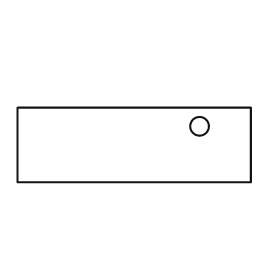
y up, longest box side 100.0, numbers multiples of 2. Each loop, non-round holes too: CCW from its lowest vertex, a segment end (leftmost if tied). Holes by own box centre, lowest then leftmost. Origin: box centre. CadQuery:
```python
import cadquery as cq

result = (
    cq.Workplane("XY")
    .moveTo(-50.0, -16.0)
    .lineTo(50.0, -16.0)
    .lineTo(50.0, 16.0)
    .lineTo(-50.0, 16.0)
    .close()
    .moveTo(28.0, 8.0)
    .circle(4.0)
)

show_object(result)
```